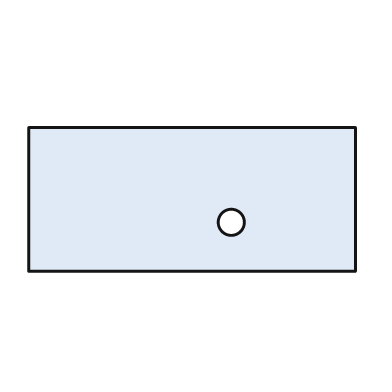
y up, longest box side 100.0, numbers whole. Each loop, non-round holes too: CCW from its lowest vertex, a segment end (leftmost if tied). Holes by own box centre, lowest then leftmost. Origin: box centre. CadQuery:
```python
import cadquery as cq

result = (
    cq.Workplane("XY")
    .moveTo(-50.0, -22.0)
    .lineTo(50.0, -22.0)
    .lineTo(50.0, 22.0)
    .lineTo(-50.0, 22.0)
    .close()
    .moveTo(12.0, -7.0)
    .circle(4.0)
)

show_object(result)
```